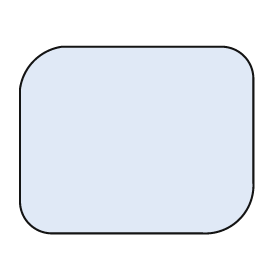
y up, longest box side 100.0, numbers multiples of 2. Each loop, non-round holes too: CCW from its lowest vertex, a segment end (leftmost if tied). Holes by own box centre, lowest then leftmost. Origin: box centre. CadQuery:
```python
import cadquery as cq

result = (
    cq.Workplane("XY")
    .moveTo(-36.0, -40.0)
    .lineTo(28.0, -40.0)
    .threePointArc((44.0, -34.0), (50.0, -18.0))
    .lineTo(50.0, 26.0)
    .threePointArc((46.0, 36.0), (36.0, 40.0))
    .lineTo(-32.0, 40.0)
    .threePointArc((-44.0, 34.0), (-50.0, 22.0))
    .lineTo(-50.0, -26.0)
    .threePointArc((-46.0, -36.0), (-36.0, -40.0))
    .close()
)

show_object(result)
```